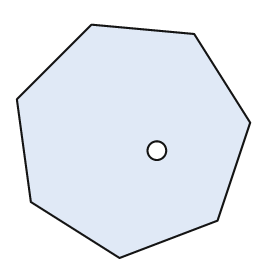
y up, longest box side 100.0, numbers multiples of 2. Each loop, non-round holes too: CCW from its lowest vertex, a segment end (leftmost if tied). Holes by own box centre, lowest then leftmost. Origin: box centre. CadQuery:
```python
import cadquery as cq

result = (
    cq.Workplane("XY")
    .moveTo(-6.0, -50.0)
    .lineTo(36.0, -34.0)
    .lineTo(50.0, 8.0)
    .lineTo(26.0, 46.0)
    .lineTo(-18.0, 50.0)
    .lineTo(-50.0, 18.0)
    .lineTo(-44.0, -26.0)
    .close()
    .moveTo(10.0, -4.0)
    .circle(4.0)
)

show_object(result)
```